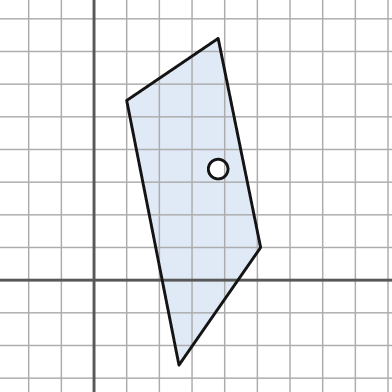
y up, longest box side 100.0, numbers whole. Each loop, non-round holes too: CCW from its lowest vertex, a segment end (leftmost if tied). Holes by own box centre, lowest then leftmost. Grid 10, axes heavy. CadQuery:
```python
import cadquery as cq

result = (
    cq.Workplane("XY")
    .moveTo(26.0, -26.0)
    .lineTo(51.0, 10.0)
    .lineTo(38.0, 74.0)
    .lineTo(10.0, 55.0)
    .close()
    .moveTo(38.0, 34.0)
    .circle(3.0)
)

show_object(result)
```